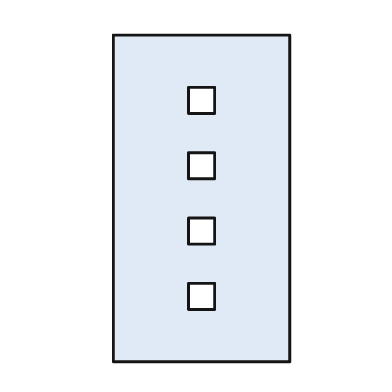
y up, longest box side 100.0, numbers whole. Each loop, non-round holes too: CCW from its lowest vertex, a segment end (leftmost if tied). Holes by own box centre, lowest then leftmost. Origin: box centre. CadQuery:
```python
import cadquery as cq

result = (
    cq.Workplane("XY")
    .moveTo(-27.0, -50.0)
    .lineTo(27.0, -50.0)
    .lineTo(27.0, 50.0)
    .lineTo(-27.0, 50.0)
    .close()
    .moveTo(-4.0, -34.0)
    .lineTo(4.0, -34.0)
    .lineTo(4.0, -26.0)
    .lineTo(-4.0, -26.0)
    .close()
    .moveTo(-4.0, -14.0)
    .lineTo(4.0, -14.0)
    .lineTo(4.0, -6.0)
    .lineTo(-4.0, -6.0)
    .close()
    .moveTo(-4.0, 6.0)
    .lineTo(4.0, 6.0)
    .lineTo(4.0, 14.0)
    .lineTo(-4.0, 14.0)
    .close()
    .moveTo(-4.0, 26.0)
    .lineTo(4.0, 26.0)
    .lineTo(4.0, 34.0)
    .lineTo(-4.0, 34.0)
    .close()
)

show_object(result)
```